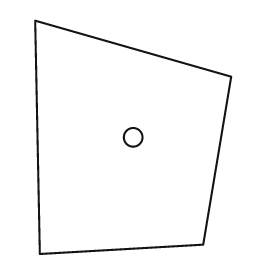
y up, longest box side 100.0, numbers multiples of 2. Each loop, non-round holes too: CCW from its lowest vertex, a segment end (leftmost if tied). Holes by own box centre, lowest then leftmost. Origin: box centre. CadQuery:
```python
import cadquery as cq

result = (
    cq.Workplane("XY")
    .moveTo(-40.0, -50.0)
    .lineTo(30.0, -46.0)
    .lineTo(42.0, 26.0)
    .lineTo(-42.0, 50.0)
    .close()
    .moveTo(0.0, 0.0)
    .circle(4.0)
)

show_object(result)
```